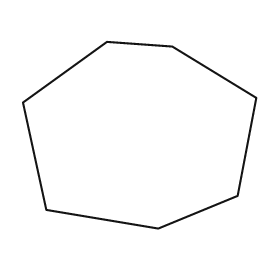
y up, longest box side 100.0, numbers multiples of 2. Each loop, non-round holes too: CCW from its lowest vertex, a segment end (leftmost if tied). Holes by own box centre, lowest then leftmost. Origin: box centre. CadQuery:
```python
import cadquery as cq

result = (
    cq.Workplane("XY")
    .moveTo(8.0, -40.0)
    .lineTo(42.0, -26.0)
    .lineTo(50.0, 16.0)
    .lineTo(14.0, 38.0)
    .lineTo(-14.0, 40.0)
    .lineTo(-50.0, 14.0)
    .lineTo(-40.0, -32.0)
    .close()
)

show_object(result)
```